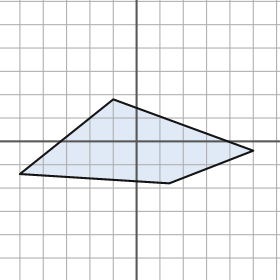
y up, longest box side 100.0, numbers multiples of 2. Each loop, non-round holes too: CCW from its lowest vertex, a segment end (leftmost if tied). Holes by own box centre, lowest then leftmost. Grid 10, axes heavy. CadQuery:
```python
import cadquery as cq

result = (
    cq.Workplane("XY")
    .moveTo(14.0, -18.0)
    .lineTo(50.0, -4.0)
    .lineTo(-10.0, 18.0)
    .lineTo(-50.0, -14.0)
    .close()
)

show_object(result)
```